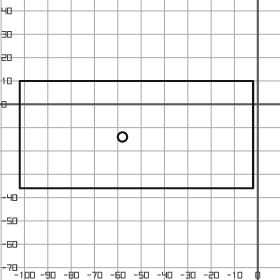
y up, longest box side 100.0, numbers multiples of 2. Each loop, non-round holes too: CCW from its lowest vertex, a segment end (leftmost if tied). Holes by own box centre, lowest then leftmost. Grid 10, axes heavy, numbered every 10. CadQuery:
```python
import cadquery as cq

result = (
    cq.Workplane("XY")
    .moveTo(-102.0, -36.0)
    .lineTo(-2.0, -36.0)
    .lineTo(-2.0, 10.0)
    .lineTo(-102.0, 10.0)
    .close()
    .moveTo(-58.0, -14.0)
    .circle(2.0)
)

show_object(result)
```